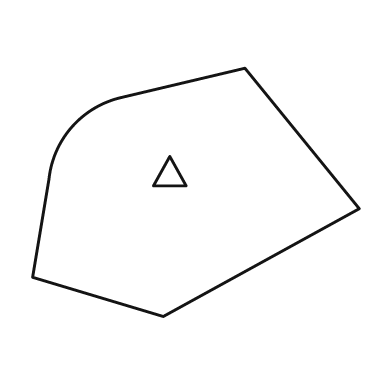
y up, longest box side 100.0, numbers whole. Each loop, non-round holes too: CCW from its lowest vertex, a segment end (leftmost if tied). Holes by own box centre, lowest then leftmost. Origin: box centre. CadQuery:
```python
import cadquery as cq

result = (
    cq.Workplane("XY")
    .moveTo(-10.0, -38.0)
    .lineTo(50.0, -5.0)
    .lineTo(15.0, 38.0)
    .lineTo(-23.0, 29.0)
    .threePointArc((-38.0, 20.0), (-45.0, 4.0))
    .lineTo(-50.0, -26.0)
    .close()
    .moveTo(-13.0, 2.0)
    .lineTo(-3.0, 2.0)
    .lineTo(-8.0, 11.0)
    .close()
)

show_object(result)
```